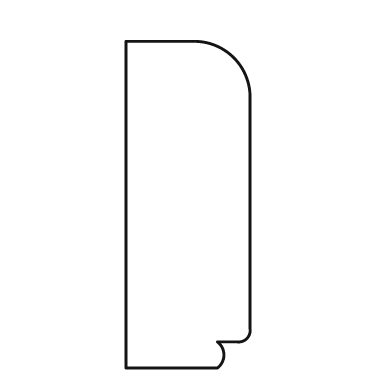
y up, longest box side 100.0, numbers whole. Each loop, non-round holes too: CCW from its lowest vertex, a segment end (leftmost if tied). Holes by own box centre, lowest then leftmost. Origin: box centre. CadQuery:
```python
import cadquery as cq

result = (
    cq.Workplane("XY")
    .moveTo(-19.0, -50.0)
    .lineTo(9.0, -50.0)
    .threePointArc((11.0, -46.0), (9.0, -42.0))
    .lineTo(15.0, -42.0)
    .threePointArc((18.0, -41.0), (19.0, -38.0))
    .lineTo(19.0, 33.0)
    .threePointArc((14.0, 45.0), (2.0, 50.0))
    .lineTo(-19.0, 50.0)
    .close()
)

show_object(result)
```